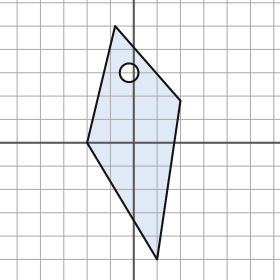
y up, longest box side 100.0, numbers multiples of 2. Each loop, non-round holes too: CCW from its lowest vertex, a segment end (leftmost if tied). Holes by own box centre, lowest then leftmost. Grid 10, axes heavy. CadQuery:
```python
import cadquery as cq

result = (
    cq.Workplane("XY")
    .moveTo(10.0, -50.0)
    .lineTo(20.0, 18.0)
    .lineTo(-8.0, 50.0)
    .lineTo(-20.0, 0.0)
    .close()
    .moveTo(-2.0, 30.0)
    .circle(4.0)
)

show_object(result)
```